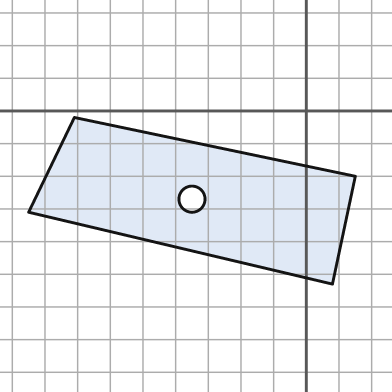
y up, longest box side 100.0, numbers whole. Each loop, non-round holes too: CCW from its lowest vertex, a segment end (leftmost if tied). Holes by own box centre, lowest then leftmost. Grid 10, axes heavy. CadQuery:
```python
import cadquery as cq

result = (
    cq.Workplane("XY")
    .moveTo(8.0, -53.0)
    .lineTo(15.0, -20.0)
    .lineTo(-71.0, -2.0)
    .lineTo(-85.0, -31.0)
    .close()
    .moveTo(-35.0, -27.0)
    .circle(4.0)
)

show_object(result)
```